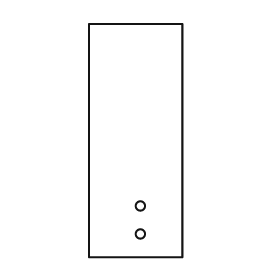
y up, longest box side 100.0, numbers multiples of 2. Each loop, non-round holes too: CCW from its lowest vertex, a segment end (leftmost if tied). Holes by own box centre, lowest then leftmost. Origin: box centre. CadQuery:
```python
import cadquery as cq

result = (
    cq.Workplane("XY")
    .moveTo(-20.0, -50.0)
    .lineTo(20.0, -50.0)
    .lineTo(20.0, 50.0)
    .lineTo(-20.0, 50.0)
    .close()
    .moveTo(2.0, -40.0)
    .circle(2.0)
    .moveTo(2.0, -28.0)
    .circle(2.0)
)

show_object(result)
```